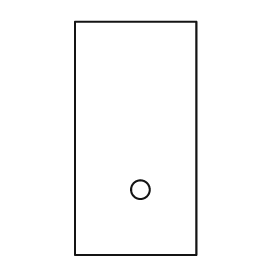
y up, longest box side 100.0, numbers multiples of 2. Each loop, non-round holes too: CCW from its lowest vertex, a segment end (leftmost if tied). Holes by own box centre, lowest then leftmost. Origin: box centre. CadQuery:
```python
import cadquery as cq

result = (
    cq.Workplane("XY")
    .moveTo(-26.0, -50.0)
    .lineTo(26.0, -50.0)
    .lineTo(26.0, 50.0)
    .lineTo(-26.0, 50.0)
    .close()
    .moveTo(2.0, -22.0)
    .circle(4.0)
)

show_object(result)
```